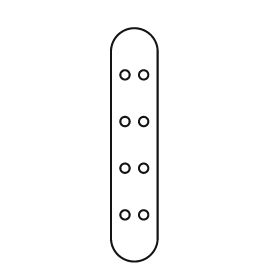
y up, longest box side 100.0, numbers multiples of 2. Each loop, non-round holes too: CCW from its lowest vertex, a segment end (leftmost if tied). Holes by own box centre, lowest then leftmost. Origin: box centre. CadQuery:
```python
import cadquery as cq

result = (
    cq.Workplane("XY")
    .moveTo(-10.0, -40.0)
    .threePointArc((0.0, -50.0), (10.0, -40.0))
    .lineTo(10.0, 40.0)
    .threePointArc((0.0, 50.0), (-10.0, 40.0))
    .close()
    .moveTo(-4.0, -30.0)
    .circle(2.0)
    .moveTo(4.0, -30.0)
    .circle(2.0)
    .moveTo(-4.0, -10.0)
    .circle(2.0)
    .moveTo(4.0, -10.0)
    .circle(2.0)
    .moveTo(-4.0, 10.0)
    .circle(2.0)
    .moveTo(4.0, 10.0)
    .circle(2.0)
    .moveTo(-4.0, 30.0)
    .circle(2.0)
    .moveTo(4.0, 30.0)
    .circle(2.0)
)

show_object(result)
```